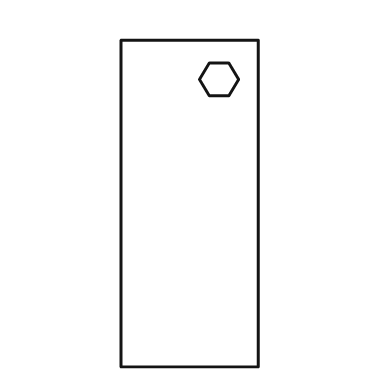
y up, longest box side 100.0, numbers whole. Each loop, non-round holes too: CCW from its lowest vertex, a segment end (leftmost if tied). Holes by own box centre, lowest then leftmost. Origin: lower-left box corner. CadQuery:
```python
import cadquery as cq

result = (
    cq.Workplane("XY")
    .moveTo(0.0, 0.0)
    .lineTo(42.0, 0.0)
    .lineTo(42.0, 100.0)
    .lineTo(0.0, 100.0)
    .close()
    .moveTo(27.0, 83.0)
    .lineTo(33.0, 83.0)
    .lineTo(36.0, 88.0)
    .lineTo(33.0, 93.0)
    .lineTo(27.0, 93.0)
    .lineTo(24.0, 88.0)
    .close()
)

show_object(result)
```